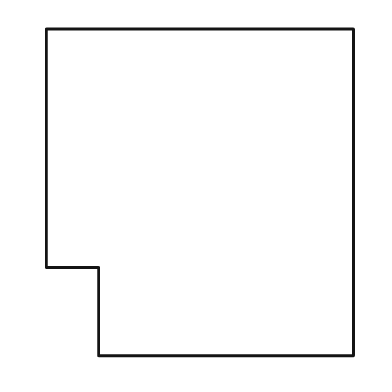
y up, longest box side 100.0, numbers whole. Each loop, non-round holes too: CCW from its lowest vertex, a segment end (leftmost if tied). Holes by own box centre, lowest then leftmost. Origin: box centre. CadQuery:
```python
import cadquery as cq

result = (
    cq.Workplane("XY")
    .moveTo(-31.0, -50.0)
    .lineTo(47.0, -50.0)
    .lineTo(47.0, 50.0)
    .lineTo(-47.0, 50.0)
    .lineTo(-47.0, -23.0)
    .lineTo(-31.0, -23.0)
    .close()
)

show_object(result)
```